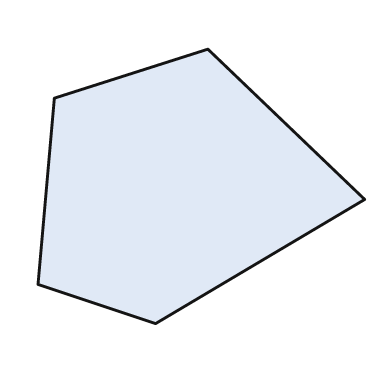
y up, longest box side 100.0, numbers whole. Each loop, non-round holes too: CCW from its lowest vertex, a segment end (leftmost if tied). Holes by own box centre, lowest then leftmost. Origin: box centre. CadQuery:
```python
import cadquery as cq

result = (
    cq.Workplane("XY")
    .moveTo(-14.0, -42.0)
    .lineTo(50.0, -4.0)
    .lineTo(2.0, 42.0)
    .lineTo(-45.0, 27.0)
    .lineTo(-50.0, -30.0)
    .close()
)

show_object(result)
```